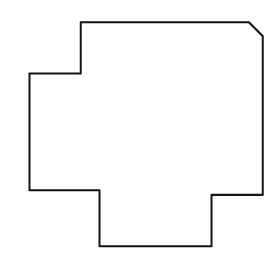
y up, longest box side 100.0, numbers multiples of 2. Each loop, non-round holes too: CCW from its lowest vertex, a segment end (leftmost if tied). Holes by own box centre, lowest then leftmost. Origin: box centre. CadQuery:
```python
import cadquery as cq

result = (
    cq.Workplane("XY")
    .moveTo(-20.0, -48.0)
    .lineTo(28.0, -48.0)
    .lineTo(28.0, -26.0)
    .lineTo(50.0, -26.0)
    .lineTo(50.0, 42.0)
    .lineTo(44.0, 48.0)
    .lineTo(-28.0, 48.0)
    .lineTo(-28.0, 26.0)
    .lineTo(-50.0, 26.0)
    .lineTo(-50.0, -24.0)
    .lineTo(-20.0, -24.0)
    .close()
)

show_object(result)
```